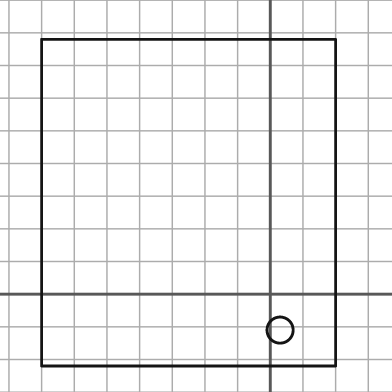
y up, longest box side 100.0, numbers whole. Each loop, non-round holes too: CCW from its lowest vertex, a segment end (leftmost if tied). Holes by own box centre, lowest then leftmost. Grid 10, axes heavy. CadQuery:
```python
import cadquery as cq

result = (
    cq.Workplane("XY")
    .moveTo(-70.0, -22.0)
    .lineTo(20.0, -22.0)
    .lineTo(20.0, 78.0)
    .lineTo(-70.0, 78.0)
    .close()
    .moveTo(3.0, -11.0)
    .circle(4.0)
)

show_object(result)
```